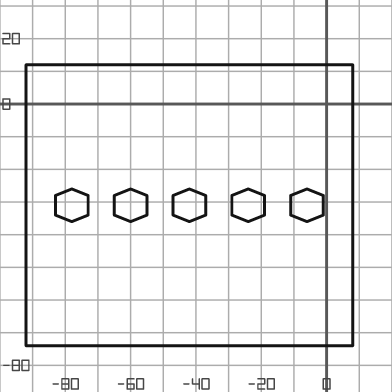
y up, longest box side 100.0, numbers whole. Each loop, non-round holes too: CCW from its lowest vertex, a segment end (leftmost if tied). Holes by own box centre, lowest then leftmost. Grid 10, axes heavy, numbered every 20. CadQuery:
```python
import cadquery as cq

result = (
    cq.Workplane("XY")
    .moveTo(-92.0, -74.0)
    .lineTo(8.0, -74.0)
    .lineTo(8.0, 12.0)
    .lineTo(-92.0, 12.0)
    .close()
    .moveTo(-78.0, -36.0)
    .lineTo(-73.0, -34.0)
    .lineTo(-73.0, -28.0)
    .lineTo(-78.0, -26.0)
    .lineTo(-83.0, -28.0)
    .lineTo(-83.0, -34.0)
    .close()
    .moveTo(-60.0, -36.0)
    .lineTo(-55.0, -34.0)
    .lineTo(-55.0, -28.0)
    .lineTo(-60.0, -26.0)
    .lineTo(-65.0, -28.0)
    .lineTo(-65.0, -34.0)
    .close()
    .moveTo(-42.0, -36.0)
    .lineTo(-37.0, -34.0)
    .lineTo(-37.0, -28.0)
    .lineTo(-42.0, -26.0)
    .lineTo(-47.0, -28.0)
    .lineTo(-47.0, -34.0)
    .close()
    .moveTo(-24.0, -36.0)
    .lineTo(-19.0, -34.0)
    .lineTo(-19.0, -28.0)
    .lineTo(-24.0, -26.0)
    .lineTo(-29.0, -28.0)
    .lineTo(-29.0, -34.0)
    .close()
    .moveTo(-6.0, -36.0)
    .lineTo(-1.0, -34.0)
    .lineTo(-1.0, -28.0)
    .lineTo(-6.0, -26.0)
    .lineTo(-11.0, -28.0)
    .lineTo(-11.0, -34.0)
    .close()
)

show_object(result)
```